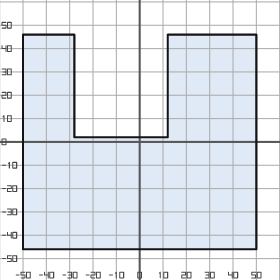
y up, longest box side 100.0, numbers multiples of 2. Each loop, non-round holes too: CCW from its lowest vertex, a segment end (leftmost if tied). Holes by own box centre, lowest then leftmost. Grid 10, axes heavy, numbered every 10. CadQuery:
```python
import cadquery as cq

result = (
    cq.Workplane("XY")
    .moveTo(-50.0, -46.0)
    .lineTo(50.0, -46.0)
    .lineTo(50.0, 46.0)
    .lineTo(12.0, 46.0)
    .lineTo(12.0, 2.0)
    .lineTo(-28.0, 2.0)
    .lineTo(-28.0, 46.0)
    .lineTo(-50.0, 46.0)
    .close()
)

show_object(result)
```